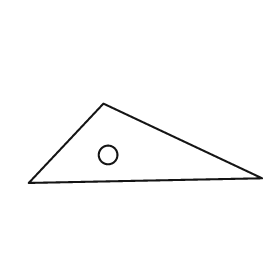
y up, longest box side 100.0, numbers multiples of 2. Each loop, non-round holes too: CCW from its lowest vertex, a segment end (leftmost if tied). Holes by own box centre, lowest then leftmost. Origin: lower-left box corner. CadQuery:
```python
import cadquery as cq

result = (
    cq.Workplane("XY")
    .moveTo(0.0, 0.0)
    .lineTo(100.0, 2.0)
    .lineTo(32.0, 34.0)
    .close()
    .moveTo(34.0, 12.0)
    .circle(4.0)
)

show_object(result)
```